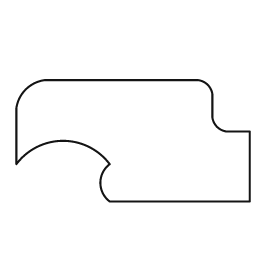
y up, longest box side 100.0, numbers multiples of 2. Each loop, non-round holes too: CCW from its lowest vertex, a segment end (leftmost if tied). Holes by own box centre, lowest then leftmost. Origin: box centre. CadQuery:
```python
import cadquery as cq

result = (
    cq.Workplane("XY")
    .moveTo(-10.0, -26.0)
    .lineTo(50.0, -26.0)
    .lineTo(50.0, 4.0)
    .lineTo(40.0, 4.0)
    .threePointArc((36.0, 6.0), (34.0, 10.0))
    .lineTo(34.0, 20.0)
    .threePointArc((32.0, 24.0), (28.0, 26.0))
    .lineTo(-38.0, 26.0)
    .threePointArc((-46.0, 22.0), (-50.0, 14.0))
    .lineTo(-50.0, -10.0)
    .threePointArc((-30.0, 0.0), (-10.0, -10.0))
    .threePointArc((-14.0, -18.0), (-10.0, -26.0))
    .close()
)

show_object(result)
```